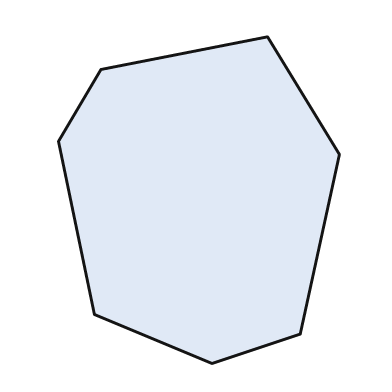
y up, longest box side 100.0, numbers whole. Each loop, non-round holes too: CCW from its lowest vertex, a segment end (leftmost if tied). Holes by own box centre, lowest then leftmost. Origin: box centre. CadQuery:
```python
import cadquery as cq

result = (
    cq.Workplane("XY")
    .moveTo(4.0, -50.0)
    .lineTo(31.0, -41.0)
    .lineTo(43.0, 14.0)
    .lineTo(21.0, 50.0)
    .lineTo(-30.0, 40.0)
    .lineTo(-43.0, 18.0)
    .lineTo(-32.0, -35.0)
    .close()
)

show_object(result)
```